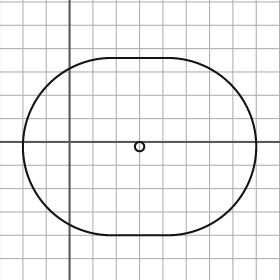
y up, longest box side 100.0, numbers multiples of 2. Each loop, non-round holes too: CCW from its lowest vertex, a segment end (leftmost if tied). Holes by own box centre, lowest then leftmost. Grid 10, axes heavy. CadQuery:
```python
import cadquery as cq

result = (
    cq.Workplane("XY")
    .moveTo(18.0, -40.0)
    .lineTo(42.0, -40.0)
    .threePointArc((80.0, -2.0), (42.0, 36.0))
    .lineTo(18.0, 36.0)
    .threePointArc((-20.0, -2.0), (18.0, -40.0))
    .close()
    .moveTo(30.0, -2.0)
    .circle(2.0)
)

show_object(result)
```